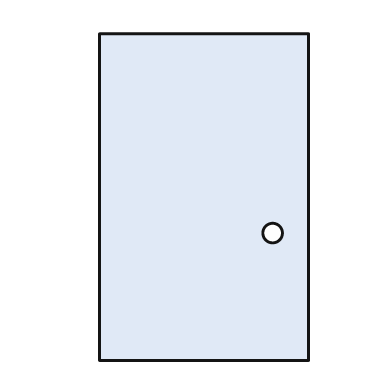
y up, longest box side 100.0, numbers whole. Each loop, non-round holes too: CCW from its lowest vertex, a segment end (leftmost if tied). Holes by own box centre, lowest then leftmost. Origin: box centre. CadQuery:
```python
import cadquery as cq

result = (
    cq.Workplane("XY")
    .moveTo(-32.0, -50.0)
    .lineTo(32.0, -50.0)
    .lineTo(32.0, 50.0)
    .lineTo(-32.0, 50.0)
    .close()
    .moveTo(21.0, -11.0)
    .circle(3.0)
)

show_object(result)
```